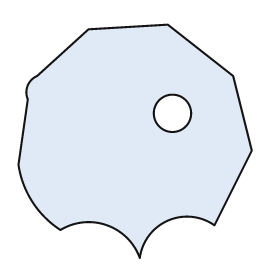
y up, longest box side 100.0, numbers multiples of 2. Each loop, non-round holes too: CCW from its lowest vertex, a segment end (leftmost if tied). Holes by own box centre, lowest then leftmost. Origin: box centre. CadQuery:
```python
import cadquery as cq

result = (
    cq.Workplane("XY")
    .moveTo(2.0, -50.0)
    .threePointArc((14.0, -34.0), (34.0, -36.0))
    .lineTo(50.0, -4.0)
    .lineTo(42.0, 28.0)
    .lineTo(14.0, 50.0)
    .lineTo(-20.0, 48.0)
    .lineTo(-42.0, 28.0)
    .threePointArc((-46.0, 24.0), (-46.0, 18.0))
    .lineTo(-50.0, -10.0)
    .threePointArc((-44.0, -26.0), (-32.0, -38.0))
    .threePointArc((-12.0, -36.0), (2.0, -50.0))
    .close()
    .moveTo(16.0, 12.0)
    .circle(8.0)
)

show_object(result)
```